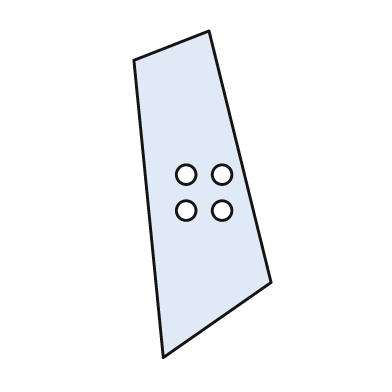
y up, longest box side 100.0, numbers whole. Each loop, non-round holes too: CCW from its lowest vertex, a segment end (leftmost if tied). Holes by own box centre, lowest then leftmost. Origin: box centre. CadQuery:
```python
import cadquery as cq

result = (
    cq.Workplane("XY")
    .moveTo(-12.0, -50.0)
    .lineTo(21.0, -27.0)
    .lineTo(2.0, 50.0)
    .lineTo(-21.0, 41.0)
    .close()
    .moveTo(-5.0, -5.0)
    .circle(3.0)
    .moveTo(6.0, -5.0)
    .circle(3.0)
    .moveTo(-5.0, 6.0)
    .circle(3.0)
    .moveTo(6.0, 6.0)
    .circle(3.0)
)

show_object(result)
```